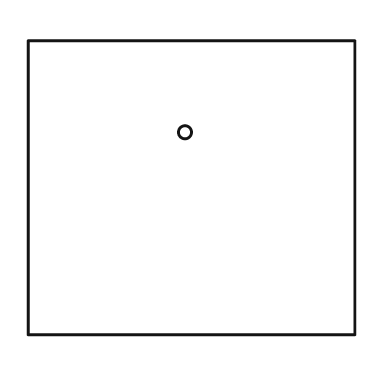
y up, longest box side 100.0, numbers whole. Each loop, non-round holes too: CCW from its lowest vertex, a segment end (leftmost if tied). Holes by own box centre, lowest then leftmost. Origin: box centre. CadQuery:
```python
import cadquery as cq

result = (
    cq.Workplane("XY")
    .moveTo(-50.0, -45.0)
    .lineTo(50.0, -45.0)
    .lineTo(50.0, 45.0)
    .lineTo(-50.0, 45.0)
    .close()
    .moveTo(-2.0, 17.0)
    .circle(2.0)
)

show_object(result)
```